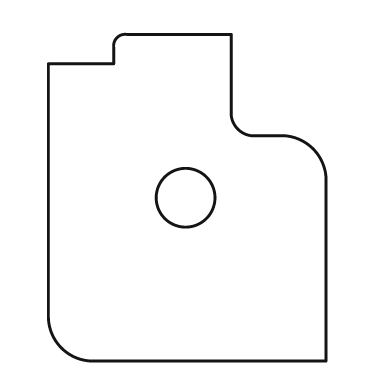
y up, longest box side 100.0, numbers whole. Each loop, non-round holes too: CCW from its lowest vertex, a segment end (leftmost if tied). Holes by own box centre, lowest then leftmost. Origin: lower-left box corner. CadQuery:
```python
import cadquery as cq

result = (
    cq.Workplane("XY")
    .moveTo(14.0, 0.0)
    .lineTo(85.0, 0.0)
    .lineTo(85.0, 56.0)
    .threePointArc((81.0, 65.0), (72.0, 69.0))
    .lineTo(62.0, 69.0)
    .threePointArc((58.0, 71.0), (56.0, 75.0))
    .lineTo(56.0, 100.0)
    .lineTo(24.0, 100.0)
    .threePointArc((21.0, 99.0), (20.0, 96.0))
    .lineTo(20.0, 91.0)
    .lineTo(0.0, 91.0)
    .lineTo(0.0, 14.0)
    .threePointArc((4.0, 4.0), (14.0, 0.0))
    .close()
    .moveTo(42.0, 50.0)
    .circle(9.0)
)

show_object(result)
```